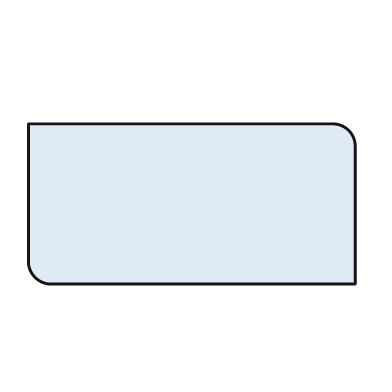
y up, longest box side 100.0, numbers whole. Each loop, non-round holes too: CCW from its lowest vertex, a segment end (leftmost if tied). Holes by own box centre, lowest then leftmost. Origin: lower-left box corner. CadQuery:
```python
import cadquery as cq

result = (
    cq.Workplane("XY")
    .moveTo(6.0, 0.0)
    .lineTo(100.0, 0.0)
    .lineTo(100.0, 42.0)
    .threePointArc((98.0, 47.0), (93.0, 49.0))
    .lineTo(0.0, 49.0)
    .lineTo(0.0, 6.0)
    .threePointArc((2.0, 2.0), (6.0, 0.0))
    .close()
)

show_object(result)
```